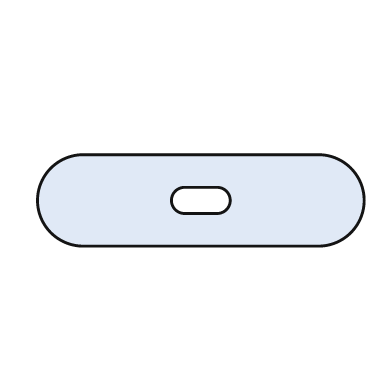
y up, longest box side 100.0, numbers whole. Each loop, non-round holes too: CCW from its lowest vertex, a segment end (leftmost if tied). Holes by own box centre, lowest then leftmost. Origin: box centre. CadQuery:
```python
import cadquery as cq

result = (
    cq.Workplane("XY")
    .moveTo(-36.0, -14.0)
    .lineTo(36.0, -14.0)
    .threePointArc((50.0, 0.0), (36.0, 14.0))
    .lineTo(-36.0, 14.0)
    .threePointArc((-50.0, 0.0), (-36.0, -14.0))
    .close()
    .moveTo(-5.0, -4.0)
    .lineTo(5.0, -4.0)
    .threePointArc((9.0, 0.0), (5.0, 4.0))
    .lineTo(-5.0, 4.0)
    .threePointArc((-9.0, 0.0), (-5.0, -4.0))
    .close()
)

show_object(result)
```